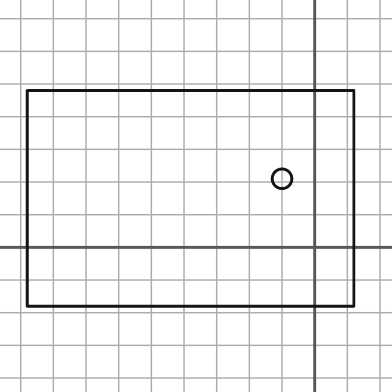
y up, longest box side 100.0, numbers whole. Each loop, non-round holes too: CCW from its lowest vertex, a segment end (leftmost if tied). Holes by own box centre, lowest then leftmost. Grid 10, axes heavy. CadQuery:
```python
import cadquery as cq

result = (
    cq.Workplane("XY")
    .moveTo(-88.0, -18.0)
    .lineTo(12.0, -18.0)
    .lineTo(12.0, 48.0)
    .lineTo(-88.0, 48.0)
    .close()
    .moveTo(-10.0, 21.0)
    .circle(3.0)
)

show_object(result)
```